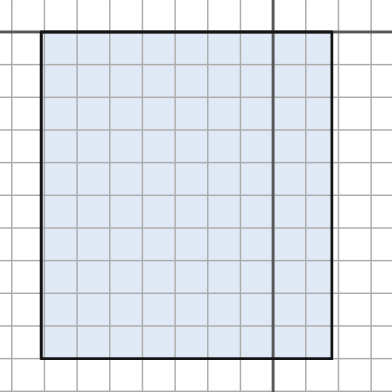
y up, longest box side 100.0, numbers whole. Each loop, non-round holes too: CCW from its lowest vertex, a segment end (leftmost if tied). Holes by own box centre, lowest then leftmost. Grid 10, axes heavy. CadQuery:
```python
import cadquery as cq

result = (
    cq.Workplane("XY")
    .moveTo(-71.0, -100.0)
    .lineTo(18.0, -100.0)
    .lineTo(18.0, 0.0)
    .lineTo(-71.0, 0.0)
    .close()
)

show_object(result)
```